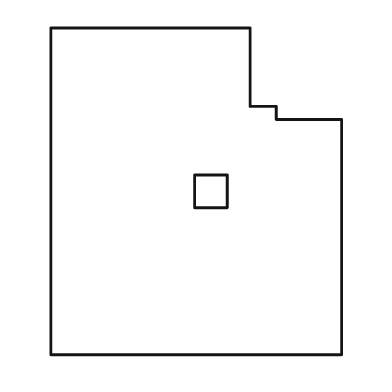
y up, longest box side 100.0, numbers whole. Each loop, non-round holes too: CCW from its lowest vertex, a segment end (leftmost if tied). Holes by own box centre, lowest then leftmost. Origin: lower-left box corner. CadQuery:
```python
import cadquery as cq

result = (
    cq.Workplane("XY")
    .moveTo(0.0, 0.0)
    .lineTo(89.0, 0.0)
    .lineTo(89.0, 72.0)
    .lineTo(69.0, 72.0)
    .lineTo(69.0, 76.0)
    .lineTo(61.0, 76.0)
    .lineTo(61.0, 100.0)
    .lineTo(0.0, 100.0)
    .close()
    .moveTo(44.0, 45.0)
    .lineTo(54.0, 45.0)
    .lineTo(54.0, 55.0)
    .lineTo(44.0, 55.0)
    .close()
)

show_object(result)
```